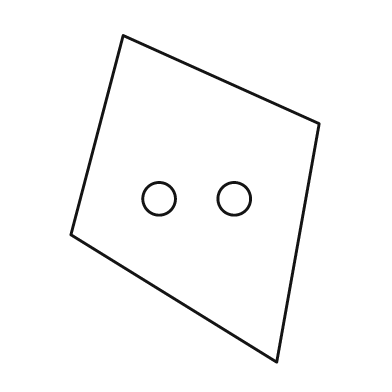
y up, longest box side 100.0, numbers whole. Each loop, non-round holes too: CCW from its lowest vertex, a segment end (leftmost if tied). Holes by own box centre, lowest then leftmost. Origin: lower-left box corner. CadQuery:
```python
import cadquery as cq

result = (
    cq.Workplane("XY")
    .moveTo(63.0, 0.0)
    .lineTo(76.0, 73.0)
    .lineTo(16.0, 100.0)
    .lineTo(0.0, 39.0)
    .close()
    .moveTo(27.0, 50.0)
    .circle(5.0)
    .moveTo(50.0, 50.0)
    .circle(5.0)
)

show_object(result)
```